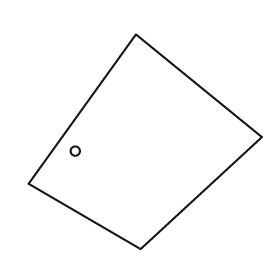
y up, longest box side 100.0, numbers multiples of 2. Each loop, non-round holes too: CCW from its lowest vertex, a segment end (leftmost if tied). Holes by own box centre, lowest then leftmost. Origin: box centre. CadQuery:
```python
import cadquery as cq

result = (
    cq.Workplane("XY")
    .moveTo(-2.0, -46.0)
    .lineTo(50.0, 2.0)
    .lineTo(-4.0, 46.0)
    .lineTo(-50.0, -18.0)
    .close()
    .moveTo(-30.0, -4.0)
    .circle(2.0)
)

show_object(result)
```